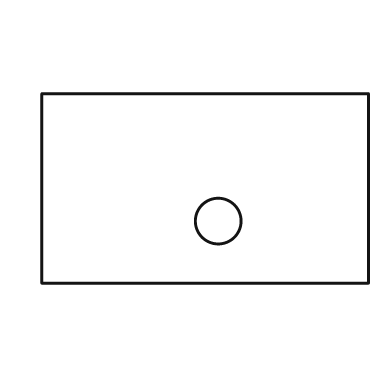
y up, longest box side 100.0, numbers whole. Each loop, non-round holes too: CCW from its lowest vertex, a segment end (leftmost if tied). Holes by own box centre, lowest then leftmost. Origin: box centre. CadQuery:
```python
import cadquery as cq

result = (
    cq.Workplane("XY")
    .moveTo(-50.0, -29.0)
    .lineTo(50.0, -29.0)
    .lineTo(50.0, 29.0)
    .lineTo(-50.0, 29.0)
    .close()
    .moveTo(4.0, -10.0)
    .circle(7.0)
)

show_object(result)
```